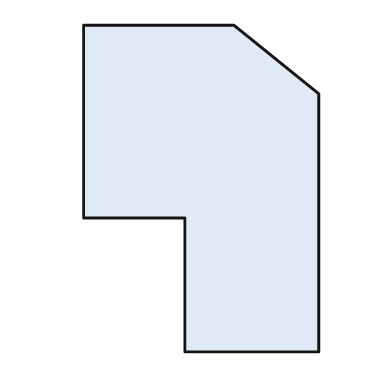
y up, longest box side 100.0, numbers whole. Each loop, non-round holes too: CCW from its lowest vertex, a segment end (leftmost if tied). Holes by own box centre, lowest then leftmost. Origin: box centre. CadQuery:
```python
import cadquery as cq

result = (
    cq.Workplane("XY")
    .moveTo(-5.0, -50.0)
    .lineTo(36.0, -50.0)
    .lineTo(36.0, 29.0)
    .lineTo(10.0, 50.0)
    .lineTo(-36.0, 50.0)
    .lineTo(-36.0, -9.0)
    .lineTo(-5.0, -9.0)
    .close()
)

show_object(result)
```